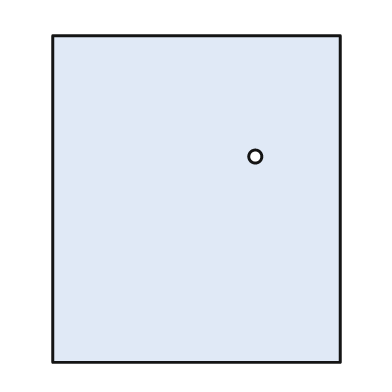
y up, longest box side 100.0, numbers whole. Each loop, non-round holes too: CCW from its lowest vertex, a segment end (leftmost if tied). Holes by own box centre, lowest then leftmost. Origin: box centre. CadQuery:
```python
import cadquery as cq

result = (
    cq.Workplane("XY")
    .moveTo(-44.0, -50.0)
    .lineTo(44.0, -50.0)
    .lineTo(44.0, 50.0)
    .lineTo(-44.0, 50.0)
    .close()
    .moveTo(18.0, 13.0)
    .circle(2.0)
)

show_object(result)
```